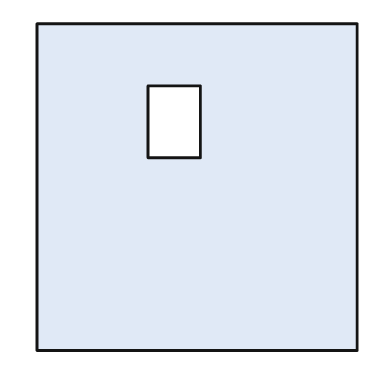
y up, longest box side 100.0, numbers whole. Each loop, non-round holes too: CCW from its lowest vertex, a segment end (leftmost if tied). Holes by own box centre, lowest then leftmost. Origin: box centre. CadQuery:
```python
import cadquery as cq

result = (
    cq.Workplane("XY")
    .moveTo(-49.0, -50.0)
    .lineTo(49.0, -50.0)
    .lineTo(49.0, 50.0)
    .lineTo(-49.0, 50.0)
    .close()
    .moveTo(-15.0, 9.0)
    .lineTo(1.0, 9.0)
    .lineTo(1.0, 31.0)
    .lineTo(-15.0, 31.0)
    .close()
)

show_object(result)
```